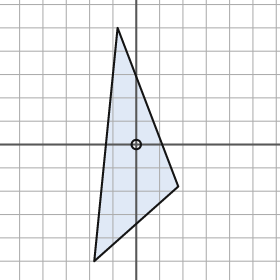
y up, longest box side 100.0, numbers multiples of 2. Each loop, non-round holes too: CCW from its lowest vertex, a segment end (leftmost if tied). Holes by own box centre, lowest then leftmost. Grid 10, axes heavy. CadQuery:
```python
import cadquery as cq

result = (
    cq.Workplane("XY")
    .moveTo(-18.0, -50.0)
    .lineTo(18.0, -18.0)
    .lineTo(-8.0, 50.0)
    .close()
    .moveTo(0.0, 0.0)
    .circle(2.0)
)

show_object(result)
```